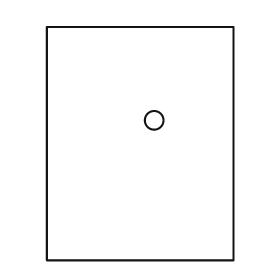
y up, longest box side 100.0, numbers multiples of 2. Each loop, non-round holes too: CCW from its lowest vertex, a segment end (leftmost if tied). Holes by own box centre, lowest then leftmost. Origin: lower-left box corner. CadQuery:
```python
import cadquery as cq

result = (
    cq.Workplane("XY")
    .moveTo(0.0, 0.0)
    .lineTo(80.0, 0.0)
    .lineTo(80.0, 100.0)
    .lineTo(0.0, 100.0)
    .close()
    .moveTo(46.0, 60.0)
    .circle(4.0)
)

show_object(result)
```